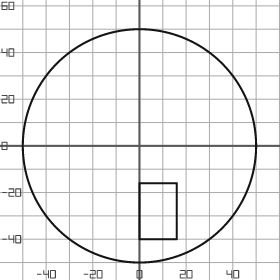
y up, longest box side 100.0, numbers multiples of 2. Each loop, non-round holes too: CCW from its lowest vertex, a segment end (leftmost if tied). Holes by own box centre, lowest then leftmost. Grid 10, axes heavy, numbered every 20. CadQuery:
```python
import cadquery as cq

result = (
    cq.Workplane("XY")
    .moveTo(0.0, 0.0)
    .circle(50.0)
    .moveTo(0.0, -40.0)
    .lineTo(16.0, -40.0)
    .lineTo(16.0, -16.0)
    .lineTo(0.0, -16.0)
    .close()
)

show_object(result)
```